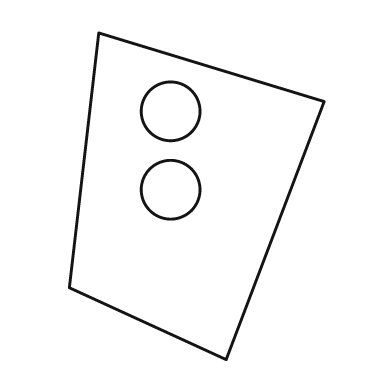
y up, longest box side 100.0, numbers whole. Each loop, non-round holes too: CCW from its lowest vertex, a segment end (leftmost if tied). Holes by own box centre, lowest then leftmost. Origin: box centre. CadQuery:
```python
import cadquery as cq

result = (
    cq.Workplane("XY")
    .moveTo(9.0, -50.0)
    .lineTo(39.0, 29.0)
    .lineTo(-30.0, 50.0)
    .lineTo(-39.0, -28.0)
    .close()
    .moveTo(-8.0, 2.0)
    .circle(9.0)
    .moveTo(-8.0, 26.0)
    .circle(9.0)
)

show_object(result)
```